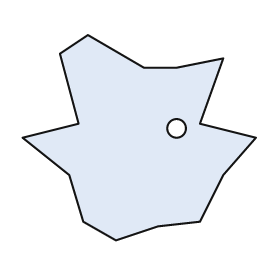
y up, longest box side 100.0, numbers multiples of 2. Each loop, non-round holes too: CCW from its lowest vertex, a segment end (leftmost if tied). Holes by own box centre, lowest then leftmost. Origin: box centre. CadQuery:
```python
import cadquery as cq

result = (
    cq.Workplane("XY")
    .moveTo(-10.0, -44.0)
    .lineTo(8.0, -38.0)
    .lineTo(26.0, -36.0)
    .lineTo(36.0, -16.0)
    .lineTo(50.0, 0.0)
    .lineTo(26.0, 6.0)
    .lineTo(36.0, 34.0)
    .lineTo(16.0, 30.0)
    .lineTo(2.0, 30.0)
    .lineTo(-22.0, 44.0)
    .lineTo(-34.0, 36.0)
    .lineTo(-26.0, 6.0)
    .lineTo(-50.0, 0.0)
    .lineTo(-30.0, -16.0)
    .lineTo(-24.0, -36.0)
    .close()
    .moveTo(16.0, 4.0)
    .circle(4.0)
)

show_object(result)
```